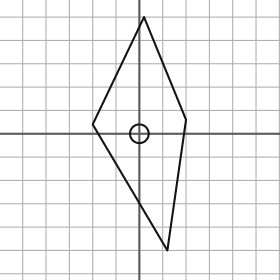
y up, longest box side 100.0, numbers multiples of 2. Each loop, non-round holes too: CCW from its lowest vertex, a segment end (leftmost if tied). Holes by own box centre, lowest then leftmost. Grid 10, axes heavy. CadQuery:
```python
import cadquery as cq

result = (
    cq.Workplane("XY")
    .moveTo(12.0, -50.0)
    .lineTo(20.0, 6.0)
    .lineTo(2.0, 50.0)
    .lineTo(-20.0, 4.0)
    .close()
    .moveTo(0.0, 0.0)
    .circle(4.0)
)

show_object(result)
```